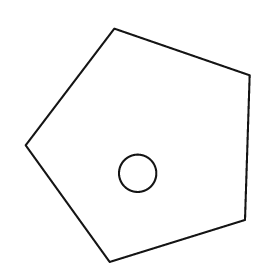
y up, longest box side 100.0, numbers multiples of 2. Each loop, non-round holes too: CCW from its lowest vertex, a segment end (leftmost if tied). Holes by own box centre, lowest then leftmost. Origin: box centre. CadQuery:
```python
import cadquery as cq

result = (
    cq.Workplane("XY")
    .moveTo(-12.0, -50.0)
    .lineTo(46.0, -32.0)
    .lineTo(48.0, 30.0)
    .lineTo(-10.0, 50.0)
    .lineTo(-48.0, 0.0)
    .close()
    .moveTo(0.0, -12.0)
    .circle(8.0)
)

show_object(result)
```